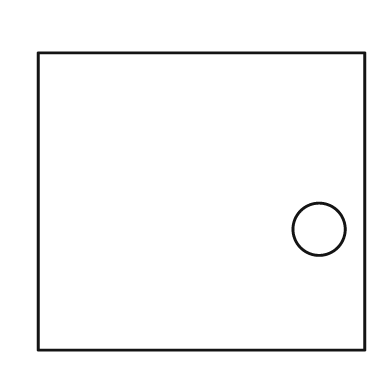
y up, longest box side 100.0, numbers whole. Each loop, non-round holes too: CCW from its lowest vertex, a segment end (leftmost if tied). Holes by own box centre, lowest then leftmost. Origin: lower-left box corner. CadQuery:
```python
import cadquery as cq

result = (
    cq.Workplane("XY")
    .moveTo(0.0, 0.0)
    .lineTo(100.0, 0.0)
    .lineTo(100.0, 91.0)
    .lineTo(0.0, 91.0)
    .close()
    .moveTo(86.0, 37.0)
    .circle(8.0)
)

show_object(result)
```